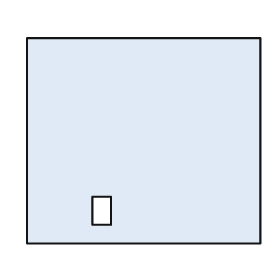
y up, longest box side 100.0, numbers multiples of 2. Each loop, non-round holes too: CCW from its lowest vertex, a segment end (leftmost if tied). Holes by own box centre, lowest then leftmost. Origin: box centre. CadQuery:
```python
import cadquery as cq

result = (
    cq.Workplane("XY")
    .moveTo(-50.0, -44.0)
    .lineTo(50.0, -44.0)
    .lineTo(50.0, 44.0)
    .lineTo(-50.0, 44.0)
    .close()
    .moveTo(-22.0, -36.0)
    .lineTo(-14.0, -36.0)
    .lineTo(-14.0, -24.0)
    .lineTo(-22.0, -24.0)
    .close()
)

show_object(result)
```